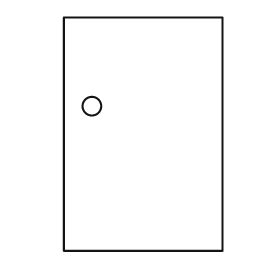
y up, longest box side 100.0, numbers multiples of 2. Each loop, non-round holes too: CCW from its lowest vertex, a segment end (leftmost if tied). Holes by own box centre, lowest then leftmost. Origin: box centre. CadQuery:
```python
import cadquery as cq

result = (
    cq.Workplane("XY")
    .moveTo(-34.0, -50.0)
    .lineTo(34.0, -50.0)
    .lineTo(34.0, 50.0)
    .lineTo(-34.0, 50.0)
    .close()
    .moveTo(-22.0, 12.0)
    .circle(4.0)
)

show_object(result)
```